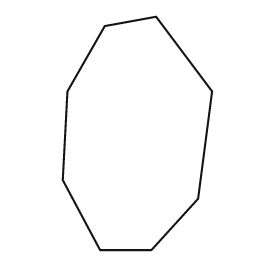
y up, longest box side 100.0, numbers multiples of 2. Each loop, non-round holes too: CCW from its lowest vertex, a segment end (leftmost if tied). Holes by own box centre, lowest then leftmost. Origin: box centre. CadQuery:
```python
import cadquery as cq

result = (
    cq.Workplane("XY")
    .moveTo(-16.0, -50.0)
    .lineTo(6.0, -50.0)
    .lineTo(26.0, -28.0)
    .lineTo(32.0, 18.0)
    .lineTo(8.0, 50.0)
    .lineTo(-14.0, 46.0)
    .lineTo(-30.0, 18.0)
    .lineTo(-32.0, -20.0)
    .close()
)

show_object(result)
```